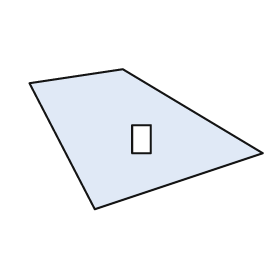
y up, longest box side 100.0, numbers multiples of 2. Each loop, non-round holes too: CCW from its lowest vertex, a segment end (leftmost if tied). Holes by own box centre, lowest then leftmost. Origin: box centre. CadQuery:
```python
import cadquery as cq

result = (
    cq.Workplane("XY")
    .moveTo(-22.0, -30.0)
    .lineTo(50.0, -6.0)
    .lineTo(-10.0, 30.0)
    .lineTo(-50.0, 24.0)
    .close()
    .moveTo(-6.0, -6.0)
    .lineTo(2.0, -6.0)
    .lineTo(2.0, 6.0)
    .lineTo(-6.0, 6.0)
    .close()
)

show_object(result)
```